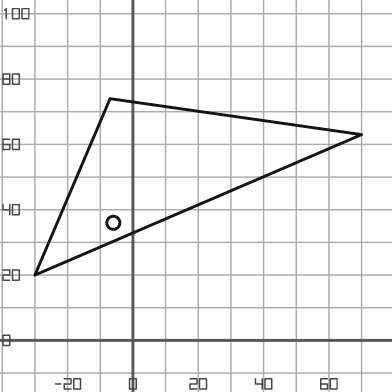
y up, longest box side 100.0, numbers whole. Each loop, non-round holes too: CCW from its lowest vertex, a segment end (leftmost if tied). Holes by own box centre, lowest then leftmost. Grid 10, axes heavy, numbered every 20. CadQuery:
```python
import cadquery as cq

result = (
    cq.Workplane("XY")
    .moveTo(-30.0, 20.0)
    .lineTo(70.0, 63.0)
    .lineTo(-7.0, 74.0)
    .close()
    .moveTo(-6.0, 36.0)
    .circle(2.0)
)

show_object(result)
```